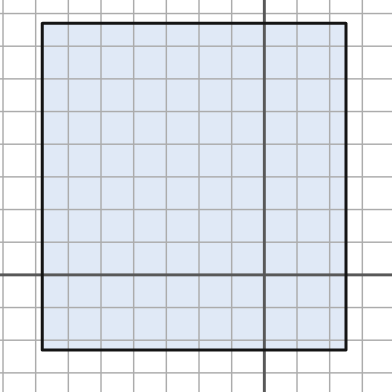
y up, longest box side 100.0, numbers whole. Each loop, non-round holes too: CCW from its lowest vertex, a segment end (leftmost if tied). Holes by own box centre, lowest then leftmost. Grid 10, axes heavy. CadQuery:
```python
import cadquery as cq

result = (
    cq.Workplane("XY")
    .moveTo(-68.0, -23.0)
    .lineTo(25.0, -23.0)
    .lineTo(25.0, 77.0)
    .lineTo(-68.0, 77.0)
    .close()
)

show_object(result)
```